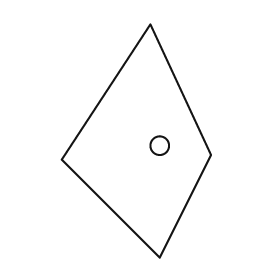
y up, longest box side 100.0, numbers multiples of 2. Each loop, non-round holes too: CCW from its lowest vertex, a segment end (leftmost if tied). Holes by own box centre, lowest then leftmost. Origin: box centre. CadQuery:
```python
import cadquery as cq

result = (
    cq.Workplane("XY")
    .moveTo(10.0, -50.0)
    .lineTo(32.0, -6.0)
    .lineTo(6.0, 50.0)
    .lineTo(-32.0, -8.0)
    .close()
    .moveTo(10.0, -2.0)
    .circle(4.0)
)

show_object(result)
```